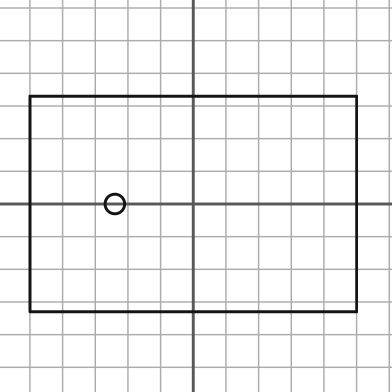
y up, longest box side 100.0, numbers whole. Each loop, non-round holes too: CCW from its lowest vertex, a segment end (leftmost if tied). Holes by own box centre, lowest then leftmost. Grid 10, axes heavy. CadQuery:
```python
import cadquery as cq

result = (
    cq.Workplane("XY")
    .moveTo(-50.0, -33.0)
    .lineTo(50.0, -33.0)
    .lineTo(50.0, 33.0)
    .lineTo(-50.0, 33.0)
    .close()
    .moveTo(-24.0, 0.0)
    .circle(3.0)
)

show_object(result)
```